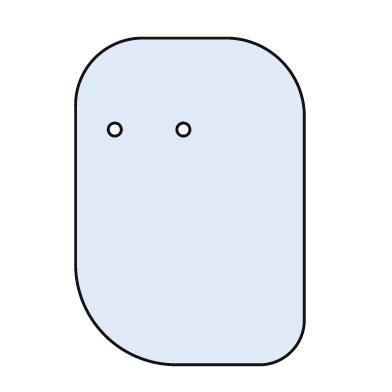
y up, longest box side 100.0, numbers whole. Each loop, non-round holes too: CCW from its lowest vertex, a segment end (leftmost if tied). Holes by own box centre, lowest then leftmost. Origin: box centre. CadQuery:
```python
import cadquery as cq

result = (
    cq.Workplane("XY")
    .moveTo(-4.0, -50.0)
    .lineTo(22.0, -50.0)
    .threePointArc((31.0, -46.0), (35.0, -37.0))
    .lineTo(35.0, 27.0)
    .threePointArc((28.0, 43.0), (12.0, 50.0))
    .lineTo(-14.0, 50.0)
    .threePointArc((-29.0, 44.0), (-35.0, 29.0))
    .lineTo(-35.0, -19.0)
    .threePointArc((-26.0, -41.0), (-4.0, -50.0))
    .close()
    .moveTo(-23.0, 22.0)
    .circle(2.0)
    .moveTo(-2.0, 22.0)
    .circle(2.0)
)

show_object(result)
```